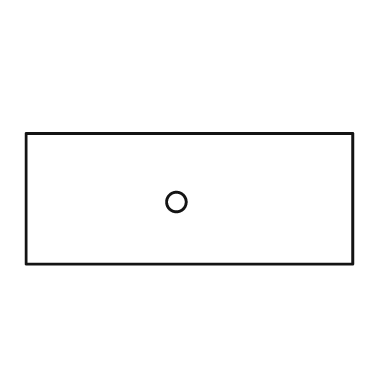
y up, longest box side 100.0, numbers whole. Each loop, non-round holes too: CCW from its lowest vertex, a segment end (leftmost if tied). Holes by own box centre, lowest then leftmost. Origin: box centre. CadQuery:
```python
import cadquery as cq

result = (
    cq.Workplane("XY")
    .moveTo(-50.0, -20.0)
    .lineTo(50.0, -20.0)
    .lineTo(50.0, 20.0)
    .lineTo(-50.0, 20.0)
    .close()
    .moveTo(-4.0, -1.0)
    .circle(3.0)
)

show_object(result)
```